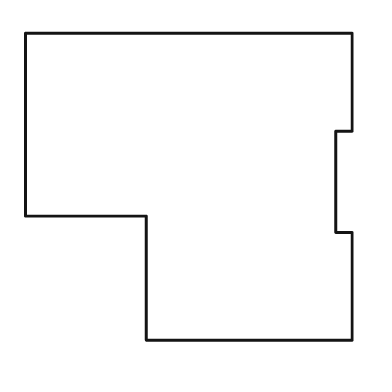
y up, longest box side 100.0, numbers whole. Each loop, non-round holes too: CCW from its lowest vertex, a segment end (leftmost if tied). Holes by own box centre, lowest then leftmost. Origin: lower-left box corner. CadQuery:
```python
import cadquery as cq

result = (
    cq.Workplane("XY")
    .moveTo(37.0, 0.0)
    .lineTo(100.0, 0.0)
    .lineTo(100.0, 33.0)
    .lineTo(95.0, 33.0)
    .lineTo(95.0, 64.0)
    .lineTo(100.0, 64.0)
    .lineTo(100.0, 94.0)
    .lineTo(0.0, 94.0)
    .lineTo(0.0, 38.0)
    .lineTo(37.0, 38.0)
    .close()
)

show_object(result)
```